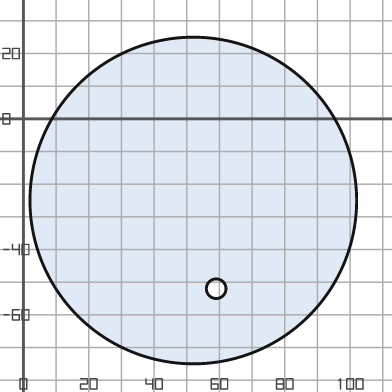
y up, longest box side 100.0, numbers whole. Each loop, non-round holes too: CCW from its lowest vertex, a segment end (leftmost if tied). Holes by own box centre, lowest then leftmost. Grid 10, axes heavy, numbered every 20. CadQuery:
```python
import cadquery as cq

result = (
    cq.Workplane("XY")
    .moveTo(52.0, -25.0)
    .circle(50.0)
    .moveTo(59.0, -52.0)
    .circle(3.0)
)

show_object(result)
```